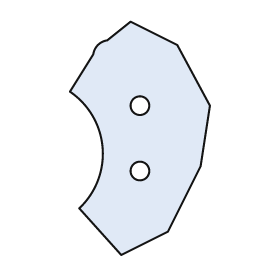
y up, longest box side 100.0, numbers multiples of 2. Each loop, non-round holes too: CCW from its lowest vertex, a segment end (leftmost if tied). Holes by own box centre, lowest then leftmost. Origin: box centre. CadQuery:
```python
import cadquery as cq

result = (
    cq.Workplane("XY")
    .moveTo(-8.0, -50.0)
    .lineTo(12.0, -40.0)
    .lineTo(26.0, -12.0)
    .lineTo(30.0, 14.0)
    .lineTo(16.0, 40.0)
    .lineTo(-4.0, 50.0)
    .lineTo(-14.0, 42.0)
    .threePointArc((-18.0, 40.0), (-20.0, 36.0))
    .lineTo(-30.0, 20.0)
    .threePointArc((-16.0, -4.0), (-26.0, -30.0))
    .close()
    .moveTo(0.0, -14.0)
    .circle(4.0)
    .moveTo(0.0, 14.0)
    .circle(4.0)
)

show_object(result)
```